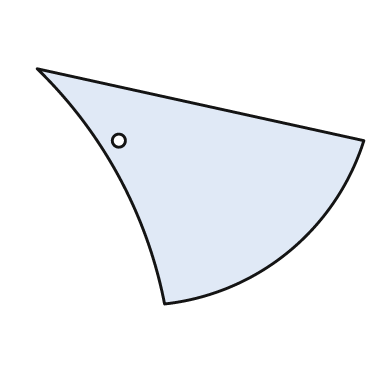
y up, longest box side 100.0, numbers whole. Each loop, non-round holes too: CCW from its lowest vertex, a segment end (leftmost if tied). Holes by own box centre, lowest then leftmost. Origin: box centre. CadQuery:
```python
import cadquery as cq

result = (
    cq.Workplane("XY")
    .moveTo(-11.0, -36.0)
    .threePointArc((27.0, -20.0), (50.0, 14.0))
    .lineTo(-50.0, 36.0)
    .threePointArc((-25.0, 3.0), (-11.0, -36.0))
    .close()
    .moveTo(-25.0, 14.0)
    .circle(2.0)
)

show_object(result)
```